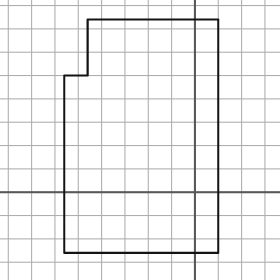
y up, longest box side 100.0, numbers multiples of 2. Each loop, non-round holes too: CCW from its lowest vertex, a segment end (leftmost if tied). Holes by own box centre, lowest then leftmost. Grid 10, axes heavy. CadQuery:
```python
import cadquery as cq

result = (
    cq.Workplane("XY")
    .moveTo(-56.0, -26.0)
    .lineTo(10.0, -26.0)
    .lineTo(10.0, 74.0)
    .lineTo(-46.0, 74.0)
    .lineTo(-46.0, 50.0)
    .lineTo(-56.0, 50.0)
    .close()
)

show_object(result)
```